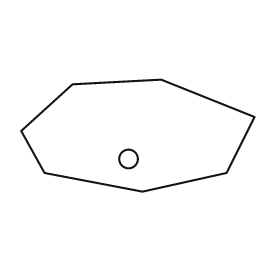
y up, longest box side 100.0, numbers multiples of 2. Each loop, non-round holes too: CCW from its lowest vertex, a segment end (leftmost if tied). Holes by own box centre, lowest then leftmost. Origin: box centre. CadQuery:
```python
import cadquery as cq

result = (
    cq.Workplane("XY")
    .moveTo(2.0, -24.0)
    .lineTo(38.0, -16.0)
    .lineTo(50.0, 8.0)
    .lineTo(10.0, 24.0)
    .lineTo(-28.0, 22.0)
    .lineTo(-50.0, 2.0)
    .lineTo(-40.0, -16.0)
    .close()
    .moveTo(-4.0, -10.0)
    .circle(4.0)
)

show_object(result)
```